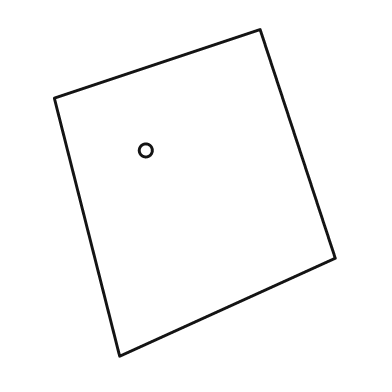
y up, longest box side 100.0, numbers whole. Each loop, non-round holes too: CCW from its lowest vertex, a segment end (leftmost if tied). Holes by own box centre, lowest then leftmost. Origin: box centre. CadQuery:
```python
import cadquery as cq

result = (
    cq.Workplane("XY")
    .moveTo(-23.0, -50.0)
    .lineTo(43.0, -20.0)
    .lineTo(20.0, 50.0)
    .lineTo(-43.0, 29.0)
    .close()
    .moveTo(-15.0, 13.0)
    .circle(2.0)
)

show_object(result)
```